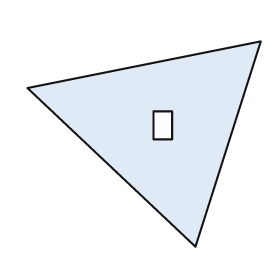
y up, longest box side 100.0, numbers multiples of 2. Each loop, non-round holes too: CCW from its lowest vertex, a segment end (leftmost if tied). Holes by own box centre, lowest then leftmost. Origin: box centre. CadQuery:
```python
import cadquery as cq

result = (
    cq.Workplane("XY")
    .moveTo(22.0, -44.0)
    .lineTo(50.0, 44.0)
    .lineTo(-50.0, 24.0)
    .close()
    .moveTo(4.0, 2.0)
    .lineTo(12.0, 2.0)
    .lineTo(12.0, 14.0)
    .lineTo(4.0, 14.0)
    .close()
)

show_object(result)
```